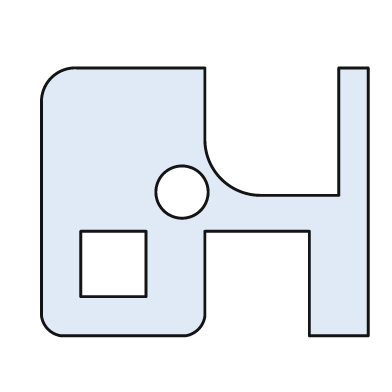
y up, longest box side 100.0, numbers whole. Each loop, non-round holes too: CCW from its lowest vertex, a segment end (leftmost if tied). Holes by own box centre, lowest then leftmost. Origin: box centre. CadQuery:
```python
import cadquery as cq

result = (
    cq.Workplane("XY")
    .moveTo(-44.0, -41.0)
    .lineTo(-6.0, -41.0)
    .threePointArc((-2.0, -39.0), (0.0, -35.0))
    .lineTo(0.0, -9.0)
    .lineTo(32.0, -9.0)
    .lineTo(32.0, -41.0)
    .lineTo(50.0, -41.0)
    .lineTo(50.0, 41.0)
    .lineTo(41.0, 41.0)
    .lineTo(41.0, 2.0)
    .lineTo(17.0, 2.0)
    .threePointArc((5.0, 7.0), (0.0, 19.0))
    .lineTo(0.0, 41.0)
    .lineTo(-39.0, 41.0)
    .threePointArc((-47.0, 38.0), (-50.0, 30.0))
    .lineTo(-50.0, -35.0)
    .threePointArc((-48.0, -39.0), (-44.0, -41.0))
    .close()
    .moveTo(-38.0, -29.0)
    .lineTo(-18.0, -29.0)
    .lineTo(-18.0, -9.0)
    .lineTo(-38.0, -9.0)
    .close()
    .moveTo(-7.0, 3.0)
    .circle(8.0)
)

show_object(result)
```